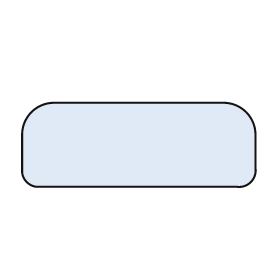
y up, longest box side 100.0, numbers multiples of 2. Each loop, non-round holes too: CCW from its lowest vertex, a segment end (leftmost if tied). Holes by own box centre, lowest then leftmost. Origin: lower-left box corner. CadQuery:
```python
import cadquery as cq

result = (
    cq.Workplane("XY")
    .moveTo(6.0, 0.0)
    .lineTo(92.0, 0.0)
    .threePointArc((98.0, 2.0), (100.0, 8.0))
    .lineTo(100.0, 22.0)
    .threePointArc((96.0, 32.0), (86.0, 36.0))
    .lineTo(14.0, 36.0)
    .threePointArc((4.0, 32.0), (0.0, 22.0))
    .lineTo(0.0, 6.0)
    .threePointArc((2.0, 2.0), (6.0, 0.0))
    .close()
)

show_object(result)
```